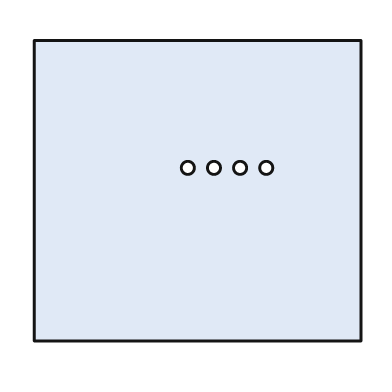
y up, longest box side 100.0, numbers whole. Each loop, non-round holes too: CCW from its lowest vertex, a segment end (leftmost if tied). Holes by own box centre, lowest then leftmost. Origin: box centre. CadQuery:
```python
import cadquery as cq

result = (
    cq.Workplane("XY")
    .moveTo(-50.0, -46.0)
    .lineTo(50.0, -46.0)
    .lineTo(50.0, 46.0)
    .lineTo(-50.0, 46.0)
    .close()
    .moveTo(-3.0, 7.0)
    .circle(2.0)
    .moveTo(5.0, 7.0)
    .circle(2.0)
    .moveTo(13.0, 7.0)
    .circle(2.0)
    .moveTo(21.0, 7.0)
    .circle(2.0)
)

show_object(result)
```